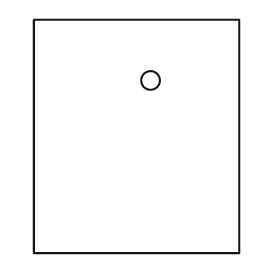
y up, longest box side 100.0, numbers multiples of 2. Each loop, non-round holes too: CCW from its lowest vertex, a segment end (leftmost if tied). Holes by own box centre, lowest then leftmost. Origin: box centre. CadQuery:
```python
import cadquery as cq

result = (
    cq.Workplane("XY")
    .moveTo(-44.0, -50.0)
    .lineTo(44.0, -50.0)
    .lineTo(44.0, 50.0)
    .lineTo(-44.0, 50.0)
    .close()
    .moveTo(6.0, 24.0)
    .circle(4.0)
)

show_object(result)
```